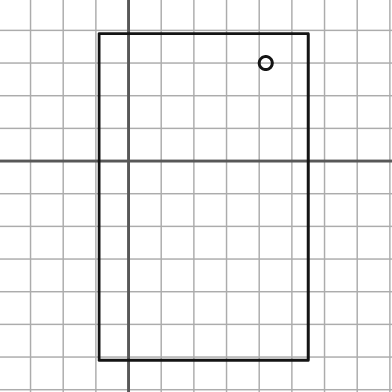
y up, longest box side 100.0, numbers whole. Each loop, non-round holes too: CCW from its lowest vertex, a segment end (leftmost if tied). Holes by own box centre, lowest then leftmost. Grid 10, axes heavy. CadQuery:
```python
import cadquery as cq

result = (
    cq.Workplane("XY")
    .moveTo(-9.0, -61.0)
    .lineTo(55.0, -61.0)
    .lineTo(55.0, 39.0)
    .lineTo(-9.0, 39.0)
    .close()
    .moveTo(42.0, 30.0)
    .circle(2.0)
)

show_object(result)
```